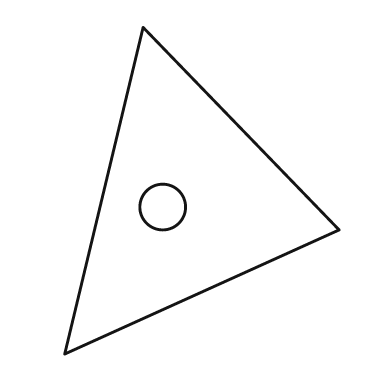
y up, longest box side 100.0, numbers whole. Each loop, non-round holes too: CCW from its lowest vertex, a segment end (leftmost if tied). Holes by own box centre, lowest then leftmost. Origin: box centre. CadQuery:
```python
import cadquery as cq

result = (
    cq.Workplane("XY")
    .moveTo(-42.0, -50.0)
    .lineTo(42.0, -12.0)
    .lineTo(-18.0, 50.0)
    .close()
    .moveTo(-12.0, -5.0)
    .circle(7.0)
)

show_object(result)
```